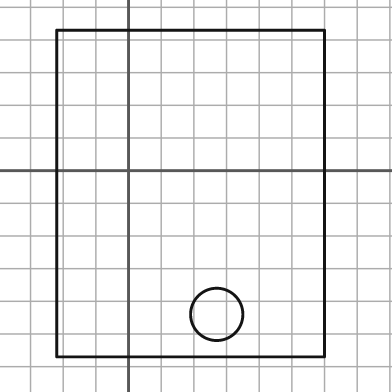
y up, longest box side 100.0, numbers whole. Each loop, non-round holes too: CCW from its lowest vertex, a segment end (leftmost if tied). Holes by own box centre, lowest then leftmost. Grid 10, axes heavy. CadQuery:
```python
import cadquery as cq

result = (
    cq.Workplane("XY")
    .moveTo(-22.0, -57.0)
    .lineTo(60.0, -57.0)
    .lineTo(60.0, 43.0)
    .lineTo(-22.0, 43.0)
    .close()
    .moveTo(27.0, -44.0)
    .circle(8.0)
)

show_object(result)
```